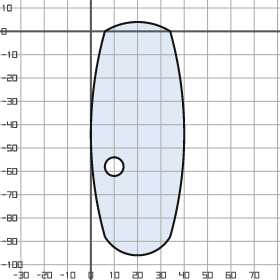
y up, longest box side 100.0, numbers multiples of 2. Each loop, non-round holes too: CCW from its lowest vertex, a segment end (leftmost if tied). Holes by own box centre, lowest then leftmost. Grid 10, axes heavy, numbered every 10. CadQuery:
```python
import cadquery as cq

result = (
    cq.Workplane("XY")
    .moveTo(6.0, -88.0)
    .threePointArc((20.0, -96.0), (34.0, -88.0))
    .threePointArc((40.0, -44.0), (34.0, 0.0))
    .threePointArc((20.0, 4.0), (6.0, 0.0))
    .threePointArc((0.0, -44.0), (6.0, -88.0))
    .close()
    .moveTo(10.0, -58.0)
    .circle(4.0)
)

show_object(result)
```